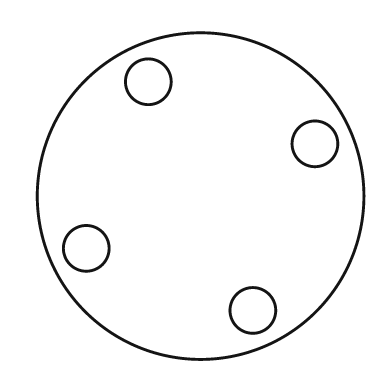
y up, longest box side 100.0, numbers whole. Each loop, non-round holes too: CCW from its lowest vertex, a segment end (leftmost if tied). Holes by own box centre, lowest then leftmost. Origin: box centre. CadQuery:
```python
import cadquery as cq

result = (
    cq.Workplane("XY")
    .moveTo(0.0, 0.0)
    .circle(50.0)
    .moveTo(16.0, -35.0)
    .circle(7.0)
    .moveTo(-35.0, -16.0)
    .circle(7.0)
    .moveTo(35.0, 16.0)
    .circle(7.0)
    .moveTo(-16.0, 35.0)
    .circle(7.0)
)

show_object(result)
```